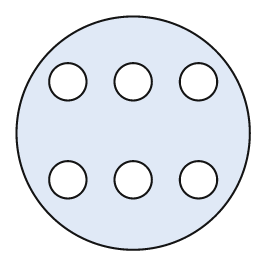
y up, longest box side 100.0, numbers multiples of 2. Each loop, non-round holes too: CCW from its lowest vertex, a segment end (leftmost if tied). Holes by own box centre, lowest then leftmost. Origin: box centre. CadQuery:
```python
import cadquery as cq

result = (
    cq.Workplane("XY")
    .moveTo(0.0, 0.0)
    .circle(50.0)
    .moveTo(-28.0, -20.0)
    .circle(8.0)
    .moveTo(0.0, -20.0)
    .circle(8.0)
    .moveTo(28.0, -20.0)
    .circle(8.0)
    .moveTo(-28.0, 22.0)
    .circle(8.0)
    .moveTo(0.0, 22.0)
    .circle(8.0)
    .moveTo(28.0, 22.0)
    .circle(8.0)
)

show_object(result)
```